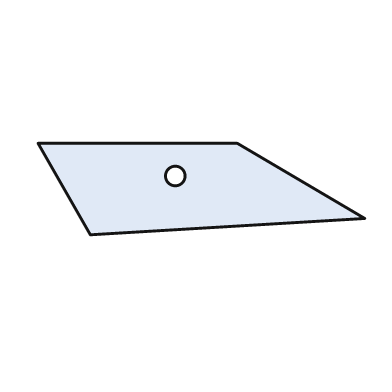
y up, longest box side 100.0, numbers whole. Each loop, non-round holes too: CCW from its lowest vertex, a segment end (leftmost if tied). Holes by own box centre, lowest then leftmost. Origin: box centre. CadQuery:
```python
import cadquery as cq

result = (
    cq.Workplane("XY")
    .moveTo(-34.0, -14.0)
    .lineTo(50.0, -9.0)
    .lineTo(11.0, 14.0)
    .lineTo(-50.0, 14.0)
    .close()
    .moveTo(-8.0, 4.0)
    .circle(3.0)
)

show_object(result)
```